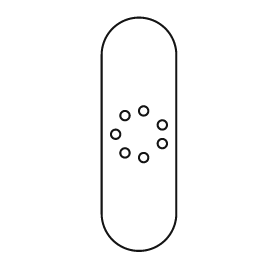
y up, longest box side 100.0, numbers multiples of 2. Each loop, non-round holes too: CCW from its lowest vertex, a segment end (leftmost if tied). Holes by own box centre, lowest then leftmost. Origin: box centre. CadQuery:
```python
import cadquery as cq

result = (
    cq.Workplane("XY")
    .moveTo(-16.0, -34.0)
    .threePointArc((0.0, -50.0), (16.0, -34.0))
    .lineTo(16.0, 34.0)
    .threePointArc((0.0, 50.0), (-16.0, 34.0))
    .close()
    .moveTo(2.0, -10.0)
    .circle(2.0)
    .moveTo(-6.0, -8.0)
    .circle(2.0)
    .moveTo(10.0, -4.0)
    .circle(2.0)
    .moveTo(-10.0, 0.0)
    .circle(2.0)
    .moveTo(10.0, 4.0)
    .circle(2.0)
    .moveTo(-6.0, 8.0)
    .circle(2.0)
    .moveTo(2.0, 10.0)
    .circle(2.0)
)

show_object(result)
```